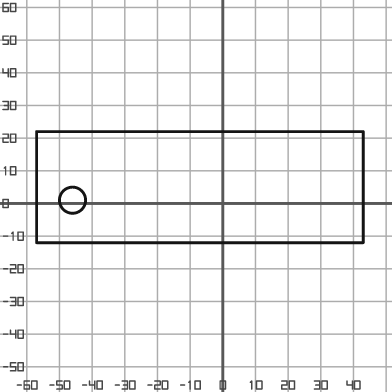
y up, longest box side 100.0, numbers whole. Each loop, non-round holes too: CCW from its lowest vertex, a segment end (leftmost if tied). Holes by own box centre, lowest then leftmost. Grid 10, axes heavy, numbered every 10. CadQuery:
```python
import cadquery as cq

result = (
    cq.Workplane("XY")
    .moveTo(-57.0, -12.0)
    .lineTo(43.0, -12.0)
    .lineTo(43.0, 22.0)
    .lineTo(-57.0, 22.0)
    .close()
    .moveTo(-46.0, 1.0)
    .circle(4.0)
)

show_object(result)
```